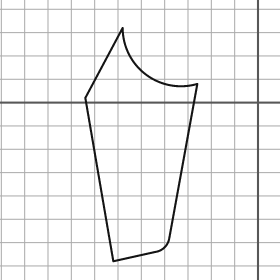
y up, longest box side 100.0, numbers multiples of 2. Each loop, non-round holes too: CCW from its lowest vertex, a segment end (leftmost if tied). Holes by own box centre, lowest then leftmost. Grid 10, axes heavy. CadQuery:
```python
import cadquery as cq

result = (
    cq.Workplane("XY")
    .moveTo(-62.0, -68.0)
    .lineTo(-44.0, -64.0)
    .threePointArc((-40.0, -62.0), (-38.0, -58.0))
    .lineTo(-26.0, 8.0)
    .threePointArc((-48.0, 12.0), (-58.0, 32.0))
    .lineTo(-74.0, 2.0)
    .close()
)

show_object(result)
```